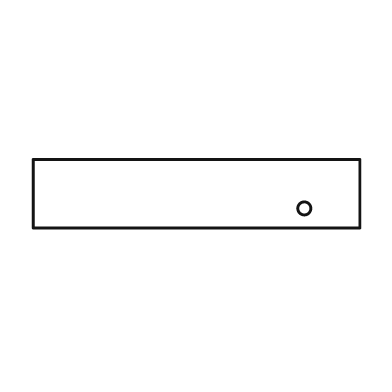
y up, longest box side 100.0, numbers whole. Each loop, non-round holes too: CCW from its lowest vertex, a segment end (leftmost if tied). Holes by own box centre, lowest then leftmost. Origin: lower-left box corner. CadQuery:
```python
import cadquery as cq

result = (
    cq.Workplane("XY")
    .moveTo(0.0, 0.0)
    .lineTo(100.0, 0.0)
    .lineTo(100.0, 21.0)
    .lineTo(0.0, 21.0)
    .close()
    .moveTo(83.0, 6.0)
    .circle(2.0)
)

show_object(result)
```